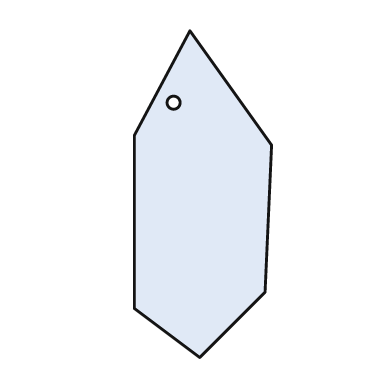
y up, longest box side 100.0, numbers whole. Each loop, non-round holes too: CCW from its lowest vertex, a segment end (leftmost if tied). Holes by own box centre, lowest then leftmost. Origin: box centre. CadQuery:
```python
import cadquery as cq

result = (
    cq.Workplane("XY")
    .moveTo(-1.0, -50.0)
    .lineTo(19.0, -30.0)
    .lineTo(21.0, 15.0)
    .lineTo(-4.0, 50.0)
    .lineTo(-21.0, 18.0)
    .lineTo(-21.0, -35.0)
    .close()
    .moveTo(-9.0, 28.0)
    .circle(2.0)
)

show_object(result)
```